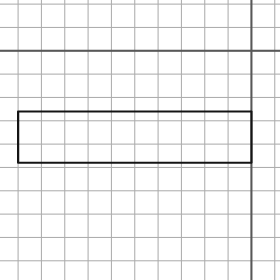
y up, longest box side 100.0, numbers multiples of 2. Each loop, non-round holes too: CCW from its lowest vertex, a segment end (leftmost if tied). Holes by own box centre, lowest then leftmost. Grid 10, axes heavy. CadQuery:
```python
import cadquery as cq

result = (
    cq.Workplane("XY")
    .moveTo(-100.0, -48.0)
    .lineTo(0.0, -48.0)
    .lineTo(0.0, -26.0)
    .lineTo(-100.0, -26.0)
    .close()
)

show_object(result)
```